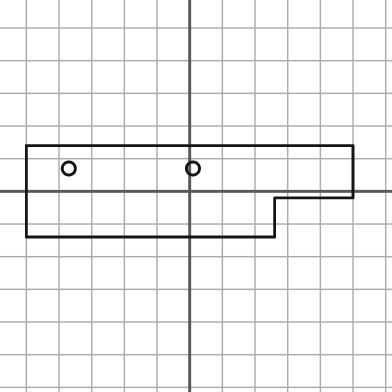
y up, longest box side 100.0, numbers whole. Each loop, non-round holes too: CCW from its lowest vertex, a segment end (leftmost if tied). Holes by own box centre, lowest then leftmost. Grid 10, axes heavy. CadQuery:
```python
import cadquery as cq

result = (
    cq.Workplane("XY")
    .moveTo(-50.0, -14.0)
    .lineTo(26.0, -14.0)
    .lineTo(26.0, -2.0)
    .lineTo(50.0, -2.0)
    .lineTo(50.0, 14.0)
    .lineTo(-50.0, 14.0)
    .close()
    .moveTo(-37.0, 7.0)
    .circle(2.0)
    .moveTo(1.0, 7.0)
    .circle(2.0)
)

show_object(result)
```